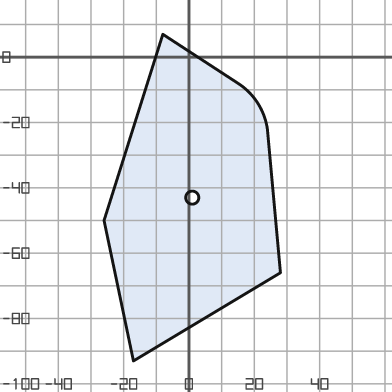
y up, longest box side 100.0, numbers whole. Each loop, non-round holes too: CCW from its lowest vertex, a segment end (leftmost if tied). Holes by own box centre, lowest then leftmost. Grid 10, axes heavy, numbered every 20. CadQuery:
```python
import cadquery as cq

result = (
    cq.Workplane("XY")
    .moveTo(-17.0, -93.0)
    .lineTo(28.0, -66.0)
    .lineTo(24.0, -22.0)
    .threePointArc((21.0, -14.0), (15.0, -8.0))
    .lineTo(-8.0, 7.0)
    .lineTo(-26.0, -50.0)
    .close()
    .moveTo(1.0, -43.0)
    .circle(2.0)
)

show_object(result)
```